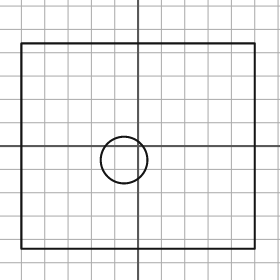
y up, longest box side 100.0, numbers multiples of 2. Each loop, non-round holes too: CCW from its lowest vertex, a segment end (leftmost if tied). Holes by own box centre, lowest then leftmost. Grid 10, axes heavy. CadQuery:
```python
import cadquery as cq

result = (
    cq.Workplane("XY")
    .moveTo(-50.0, -44.0)
    .lineTo(50.0, -44.0)
    .lineTo(50.0, 44.0)
    .lineTo(-50.0, 44.0)
    .close()
    .moveTo(-6.0, -6.0)
    .circle(10.0)
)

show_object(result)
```